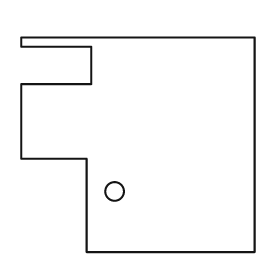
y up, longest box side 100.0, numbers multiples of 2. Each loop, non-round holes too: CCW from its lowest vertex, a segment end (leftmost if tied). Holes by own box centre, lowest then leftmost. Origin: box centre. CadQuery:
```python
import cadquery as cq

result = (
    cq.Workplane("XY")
    .moveTo(-22.0, -46.0)
    .lineTo(50.0, -46.0)
    .lineTo(50.0, 46.0)
    .lineTo(-50.0, 46.0)
    .lineTo(-50.0, 42.0)
    .lineTo(-20.0, 42.0)
    .lineTo(-20.0, 26.0)
    .lineTo(-50.0, 26.0)
    .lineTo(-50.0, -6.0)
    .lineTo(-22.0, -6.0)
    .close()
    .moveTo(-10.0, -20.0)
    .circle(4.0)
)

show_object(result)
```